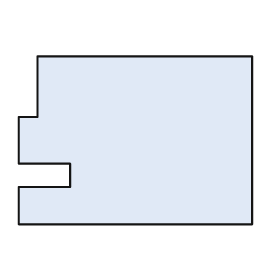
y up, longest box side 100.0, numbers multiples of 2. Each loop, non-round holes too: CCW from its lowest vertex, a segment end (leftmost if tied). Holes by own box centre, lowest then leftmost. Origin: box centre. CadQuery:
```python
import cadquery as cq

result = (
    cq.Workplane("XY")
    .moveTo(-50.0, -36.0)
    .lineTo(50.0, -36.0)
    .lineTo(50.0, 36.0)
    .lineTo(-42.0, 36.0)
    .lineTo(-42.0, 10.0)
    .lineTo(-50.0, 10.0)
    .lineTo(-50.0, -10.0)
    .lineTo(-28.0, -10.0)
    .lineTo(-28.0, -20.0)
    .lineTo(-50.0, -20.0)
    .close()
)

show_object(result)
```